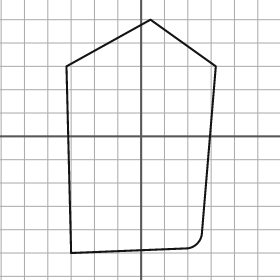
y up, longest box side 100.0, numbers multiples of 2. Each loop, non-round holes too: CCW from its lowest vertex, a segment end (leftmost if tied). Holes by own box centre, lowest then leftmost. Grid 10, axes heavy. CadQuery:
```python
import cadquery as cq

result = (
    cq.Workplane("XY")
    .moveTo(-30.0, -50.0)
    .lineTo(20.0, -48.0)
    .threePointArc((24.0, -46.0), (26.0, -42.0))
    .lineTo(32.0, 30.0)
    .lineTo(4.0, 50.0)
    .lineTo(-32.0, 30.0)
    .close()
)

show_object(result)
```